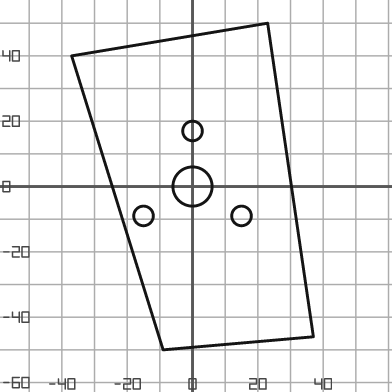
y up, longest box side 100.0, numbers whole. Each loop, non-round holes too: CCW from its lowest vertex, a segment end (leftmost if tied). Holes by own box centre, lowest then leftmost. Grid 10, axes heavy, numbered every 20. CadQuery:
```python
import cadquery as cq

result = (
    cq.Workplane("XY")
    .moveTo(-9.0, -50.0)
    .lineTo(37.0, -46.0)
    .lineTo(23.0, 50.0)
    .lineTo(-37.0, 40.0)
    .close()
    .moveTo(-15.0, -9.0)
    .circle(3.0)
    .moveTo(15.0, -9.0)
    .circle(3.0)
    .moveTo(0.0, 0.0)
    .circle(6.0)
    .moveTo(0.0, 17.0)
    .circle(3.0)
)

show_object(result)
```